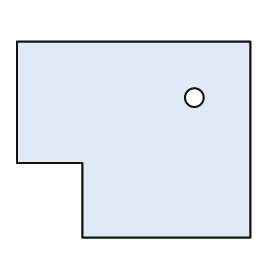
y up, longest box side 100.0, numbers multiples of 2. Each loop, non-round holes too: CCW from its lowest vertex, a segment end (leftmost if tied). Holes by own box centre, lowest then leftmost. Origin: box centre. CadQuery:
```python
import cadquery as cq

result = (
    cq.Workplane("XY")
    .moveTo(-22.0, -42.0)
    .lineTo(50.0, -42.0)
    .lineTo(50.0, 42.0)
    .lineTo(-50.0, 42.0)
    .lineTo(-50.0, -10.0)
    .lineTo(-22.0, -10.0)
    .close()
    .moveTo(26.0, 18.0)
    .circle(4.0)
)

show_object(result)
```